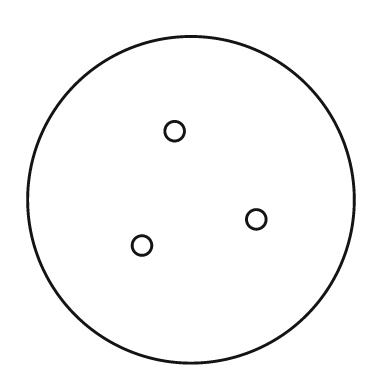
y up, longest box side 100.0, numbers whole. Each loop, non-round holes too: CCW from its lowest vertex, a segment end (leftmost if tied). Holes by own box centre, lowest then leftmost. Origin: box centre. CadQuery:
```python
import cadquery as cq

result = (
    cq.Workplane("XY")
    .moveTo(0.0, 0.0)
    .circle(50.0)
    .moveTo(-15.0, -14.0)
    .circle(3.0)
    .moveTo(20.0, -6.0)
    .circle(3.0)
    .moveTo(-5.0, 21.0)
    .circle(3.0)
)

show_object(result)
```